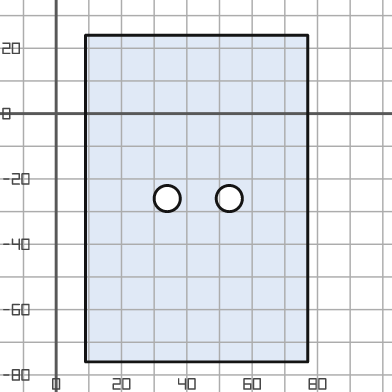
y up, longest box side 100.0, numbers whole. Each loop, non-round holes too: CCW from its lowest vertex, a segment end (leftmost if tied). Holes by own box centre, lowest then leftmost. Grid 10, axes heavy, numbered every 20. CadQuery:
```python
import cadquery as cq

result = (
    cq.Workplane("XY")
    .moveTo(9.0, -76.0)
    .lineTo(77.0, -76.0)
    .lineTo(77.0, 24.0)
    .lineTo(9.0, 24.0)
    .close()
    .moveTo(34.0, -26.0)
    .circle(4.0)
    .moveTo(53.0, -26.0)
    .circle(4.0)
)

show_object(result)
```